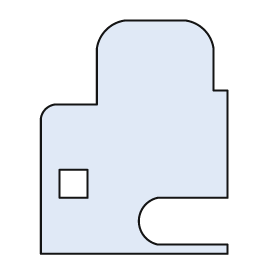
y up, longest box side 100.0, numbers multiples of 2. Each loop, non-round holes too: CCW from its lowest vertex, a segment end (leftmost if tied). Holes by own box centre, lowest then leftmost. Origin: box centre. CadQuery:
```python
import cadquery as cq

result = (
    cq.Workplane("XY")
    .moveTo(-40.0, -50.0)
    .lineTo(40.0, -50.0)
    .lineTo(40.0, -46.0)
    .lineTo(10.0, -46.0)
    .threePointArc((2.0, -36.0), (10.0, -26.0))
    .lineTo(40.0, -26.0)
    .lineTo(40.0, 20.0)
    .lineTo(34.0, 20.0)
    .lineTo(34.0, 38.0)
    .threePointArc((30.0, 46.0), (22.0, 50.0))
    .lineTo(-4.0, 50.0)
    .threePointArc((-12.0, 46.0), (-16.0, 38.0))
    .lineTo(-16.0, 14.0)
    .lineTo(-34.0, 14.0)
    .threePointArc((-38.0, 12.0), (-40.0, 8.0))
    .close()
    .moveTo(-32.0, -26.0)
    .lineTo(-20.0, -26.0)
    .lineTo(-20.0, -14.0)
    .lineTo(-32.0, -14.0)
    .close()
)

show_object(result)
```